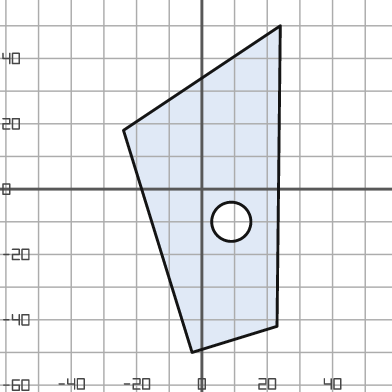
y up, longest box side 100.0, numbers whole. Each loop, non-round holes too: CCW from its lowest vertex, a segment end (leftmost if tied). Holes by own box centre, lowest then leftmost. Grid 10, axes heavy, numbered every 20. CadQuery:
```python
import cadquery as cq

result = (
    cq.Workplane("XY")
    .moveTo(-3.0, -50.0)
    .lineTo(23.0, -42.0)
    .lineTo(24.0, 50.0)
    .lineTo(-24.0, 18.0)
    .close()
    .moveTo(9.0, -10.0)
    .circle(6.0)
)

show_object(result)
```